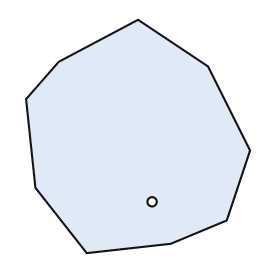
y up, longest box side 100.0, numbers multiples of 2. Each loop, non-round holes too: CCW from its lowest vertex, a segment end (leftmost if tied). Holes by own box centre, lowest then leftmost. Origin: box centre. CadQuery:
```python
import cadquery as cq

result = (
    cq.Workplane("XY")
    .moveTo(-22.0, -50.0)
    .lineTo(14.0, -46.0)
    .lineTo(38.0, -36.0)
    .lineTo(48.0, -6.0)
    .lineTo(30.0, 30.0)
    .lineTo(0.0, 50.0)
    .lineTo(-34.0, 32.0)
    .lineTo(-48.0, 16.0)
    .lineTo(-44.0, -22.0)
    .close()
    .moveTo(6.0, -28.0)
    .circle(2.0)
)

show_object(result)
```